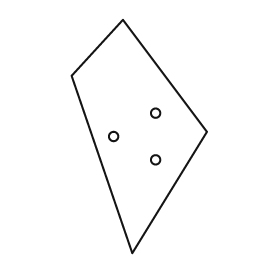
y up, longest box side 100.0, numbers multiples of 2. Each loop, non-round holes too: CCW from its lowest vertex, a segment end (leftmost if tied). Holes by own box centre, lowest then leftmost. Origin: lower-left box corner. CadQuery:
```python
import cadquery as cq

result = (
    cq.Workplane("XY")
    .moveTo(26.0, 0.0)
    .lineTo(58.0, 52.0)
    .lineTo(22.0, 100.0)
    .lineTo(0.0, 76.0)
    .close()
    .moveTo(36.0, 40.0)
    .circle(2.0)
    .moveTo(18.0, 50.0)
    .circle(2.0)
    .moveTo(36.0, 60.0)
    .circle(2.0)
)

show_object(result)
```